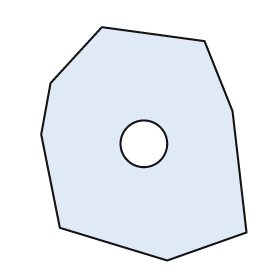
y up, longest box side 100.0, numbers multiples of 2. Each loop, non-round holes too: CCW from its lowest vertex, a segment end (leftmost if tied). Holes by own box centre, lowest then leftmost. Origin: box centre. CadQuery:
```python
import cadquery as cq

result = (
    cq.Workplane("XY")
    .moveTo(10.0, -50.0)
    .lineTo(44.0, -38.0)
    .lineTo(38.0, 14.0)
    .lineTo(26.0, 44.0)
    .lineTo(-18.0, 50.0)
    .lineTo(-40.0, 26.0)
    .lineTo(-44.0, 4.0)
    .lineTo(-36.0, -36.0)
    .close()
    .moveTo(0.0, 0.0)
    .circle(10.0)
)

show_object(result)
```